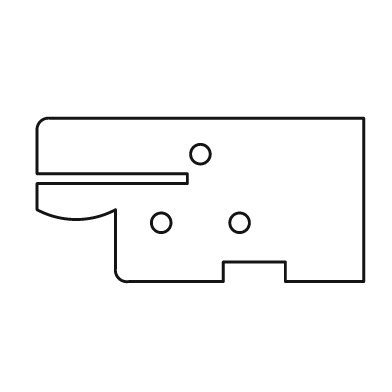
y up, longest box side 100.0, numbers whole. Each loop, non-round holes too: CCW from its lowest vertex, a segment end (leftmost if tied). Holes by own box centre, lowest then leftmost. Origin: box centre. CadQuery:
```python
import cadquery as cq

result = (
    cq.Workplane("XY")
    .moveTo(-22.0, -25.0)
    .lineTo(7.0, -25.0)
    .lineTo(7.0, -19.0)
    .lineTo(26.0, -19.0)
    .lineTo(26.0, -25.0)
    .lineTo(50.0, -25.0)
    .lineTo(50.0, 25.0)
    .lineTo(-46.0, 25.0)
    .threePointArc((-49.0, 24.0), (-50.0, 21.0))
    .lineTo(-50.0, 8.0)
    .lineTo(-4.0, 8.0)
    .lineTo(-4.0, 5.0)
    .lineTo(-50.0, 5.0)
    .lineTo(-50.0, -3.0)
    .threePointArc((-38.0, -6.0), (-26.0, -3.0))
    .lineTo(-26.0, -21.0)
    .threePointArc((-25.0, -24.0), (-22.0, -25.0))
    .close()
    .moveTo(-12.0, -7.0)
    .circle(3.0)
    .moveTo(12.0, -7.0)
    .circle(3.0)
    .moveTo(0.0, 14.0)
    .circle(3.0)
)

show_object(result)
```